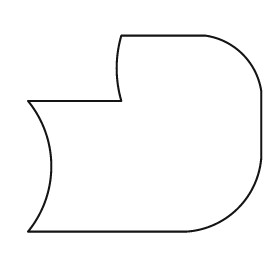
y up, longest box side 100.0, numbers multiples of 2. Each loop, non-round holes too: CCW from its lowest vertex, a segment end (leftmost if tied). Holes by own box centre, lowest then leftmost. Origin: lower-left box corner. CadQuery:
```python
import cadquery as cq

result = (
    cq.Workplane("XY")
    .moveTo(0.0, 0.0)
    .lineTo(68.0, 0.0)
    .threePointArc((90.0, 10.0), (100.0, 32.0))
    .lineTo(100.0, 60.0)
    .threePointArc((92.0, 76.0), (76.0, 84.0))
    .lineTo(40.0, 84.0)
    .threePointArc((38.0, 70.0), (40.0, 56.0))
    .lineTo(0.0, 56.0)
    .threePointArc((10.0, 28.0), (0.0, 0.0))
    .close()
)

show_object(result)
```